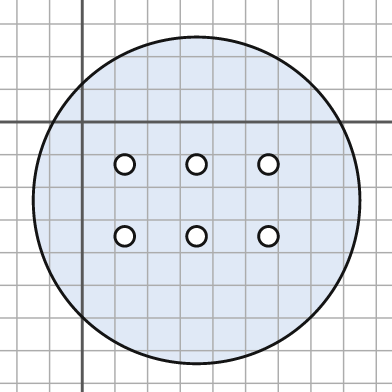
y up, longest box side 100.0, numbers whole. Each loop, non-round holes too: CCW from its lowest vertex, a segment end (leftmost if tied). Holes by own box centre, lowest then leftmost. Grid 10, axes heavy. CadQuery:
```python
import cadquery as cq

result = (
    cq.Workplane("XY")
    .moveTo(35.0, -24.0)
    .circle(50.0)
    .moveTo(13.0, -35.0)
    .circle(3.0)
    .moveTo(35.0, -35.0)
    .circle(3.0)
    .moveTo(57.0, -35.0)
    .circle(3.0)
    .moveTo(13.0, -13.0)
    .circle(3.0)
    .moveTo(35.0, -13.0)
    .circle(3.0)
    .moveTo(57.0, -13.0)
    .circle(3.0)
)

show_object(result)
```